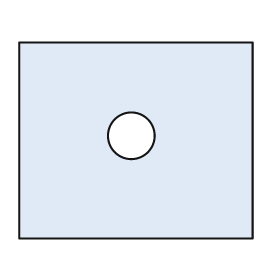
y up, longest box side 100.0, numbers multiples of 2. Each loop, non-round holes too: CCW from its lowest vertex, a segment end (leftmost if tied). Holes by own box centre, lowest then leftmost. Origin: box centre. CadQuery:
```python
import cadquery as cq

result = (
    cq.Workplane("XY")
    .moveTo(-50.0, -42.0)
    .lineTo(50.0, -42.0)
    .lineTo(50.0, 42.0)
    .lineTo(-50.0, 42.0)
    .close()
    .moveTo(-2.0, 2.0)
    .circle(10.0)
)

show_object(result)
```